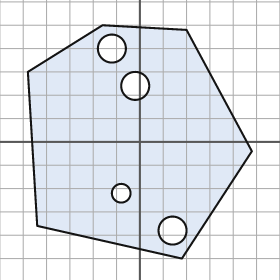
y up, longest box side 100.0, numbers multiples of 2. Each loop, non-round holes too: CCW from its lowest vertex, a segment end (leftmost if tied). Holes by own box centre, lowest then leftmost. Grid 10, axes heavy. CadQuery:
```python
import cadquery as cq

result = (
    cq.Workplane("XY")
    .moveTo(18.0, -50.0)
    .lineTo(48.0, -4.0)
    .lineTo(20.0, 48.0)
    .lineTo(-16.0, 50.0)
    .lineTo(-48.0, 30.0)
    .lineTo(-44.0, -36.0)
    .close()
    .moveTo(14.0, -38.0)
    .circle(6.0)
    .moveTo(-8.0, -22.0)
    .circle(4.0)
    .moveTo(-2.0, 24.0)
    .circle(6.0)
    .moveTo(-12.0, 40.0)
    .circle(6.0)
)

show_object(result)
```